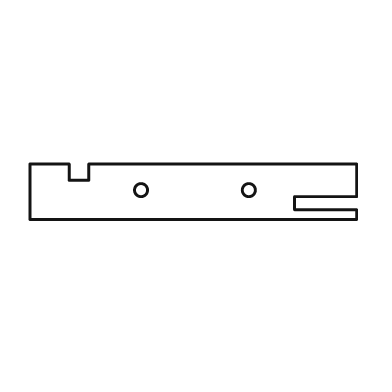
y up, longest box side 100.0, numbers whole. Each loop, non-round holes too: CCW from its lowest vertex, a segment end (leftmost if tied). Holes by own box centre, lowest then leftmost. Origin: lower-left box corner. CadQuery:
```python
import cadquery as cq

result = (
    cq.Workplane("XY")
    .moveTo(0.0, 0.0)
    .lineTo(100.0, 0.0)
    .lineTo(100.0, 3.0)
    .lineTo(81.0, 3.0)
    .lineTo(81.0, 7.0)
    .lineTo(100.0, 7.0)
    .lineTo(100.0, 17.0)
    .lineTo(18.0, 17.0)
    .lineTo(18.0, 12.0)
    .lineTo(12.0, 12.0)
    .lineTo(12.0, 17.0)
    .lineTo(0.0, 17.0)
    .close()
    .moveTo(34.0, 9.0)
    .circle(2.0)
    .moveTo(67.0, 9.0)
    .circle(2.0)
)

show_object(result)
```